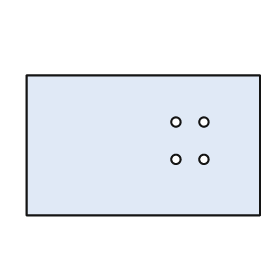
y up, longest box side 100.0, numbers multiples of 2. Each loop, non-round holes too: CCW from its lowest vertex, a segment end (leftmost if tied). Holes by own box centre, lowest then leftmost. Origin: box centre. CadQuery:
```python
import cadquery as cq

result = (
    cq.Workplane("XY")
    .moveTo(-50.0, -30.0)
    .lineTo(50.0, -30.0)
    .lineTo(50.0, 30.0)
    .lineTo(-50.0, 30.0)
    .close()
    .moveTo(14.0, -6.0)
    .circle(2.0)
    .moveTo(26.0, -6.0)
    .circle(2.0)
    .moveTo(14.0, 10.0)
    .circle(2.0)
    .moveTo(26.0, 10.0)
    .circle(2.0)
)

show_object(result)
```